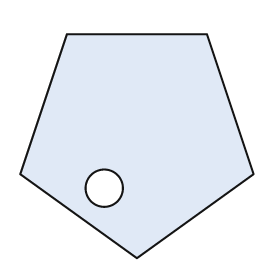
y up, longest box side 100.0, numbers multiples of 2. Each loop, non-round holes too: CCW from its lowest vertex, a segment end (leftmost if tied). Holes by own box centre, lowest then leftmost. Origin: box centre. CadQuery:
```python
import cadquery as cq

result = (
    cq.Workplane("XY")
    .moveTo(0.0, -48.0)
    .lineTo(50.0, -12.0)
    .lineTo(30.0, 48.0)
    .lineTo(-30.0, 48.0)
    .lineTo(-50.0, -12.0)
    .close()
    .moveTo(-14.0, -18.0)
    .circle(8.0)
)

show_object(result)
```